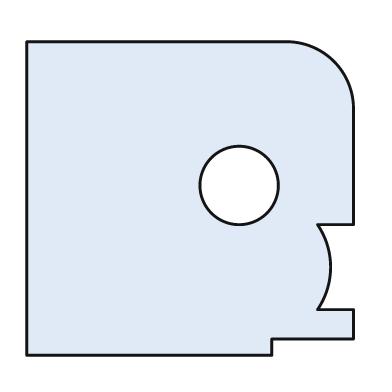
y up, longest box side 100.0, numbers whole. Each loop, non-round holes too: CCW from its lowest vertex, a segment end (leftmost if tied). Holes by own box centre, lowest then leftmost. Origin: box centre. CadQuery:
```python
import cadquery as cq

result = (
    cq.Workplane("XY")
    .moveTo(-50.0, -48.0)
    .lineTo(25.0, -48.0)
    .lineTo(25.0, -43.0)
    .lineTo(50.0, -43.0)
    .lineTo(50.0, -34.0)
    .lineTo(39.0, -34.0)
    .threePointArc((43.0, -21.0), (39.0, -8.0))
    .lineTo(50.0, -8.0)
    .lineTo(50.0, 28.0)
    .threePointArc((44.0, 42.0), (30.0, 48.0))
    .lineTo(-50.0, 48.0)
    .close()
    .moveTo(15.0, 4.0)
    .circle(12.0)
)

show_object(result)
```